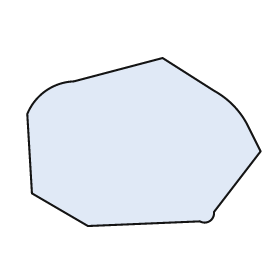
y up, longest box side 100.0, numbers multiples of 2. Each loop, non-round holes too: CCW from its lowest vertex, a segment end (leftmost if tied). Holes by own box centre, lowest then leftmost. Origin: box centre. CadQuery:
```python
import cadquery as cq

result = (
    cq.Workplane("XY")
    .moveTo(-24.0, -36.0)
    .lineTo(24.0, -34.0)
    .threePointArc((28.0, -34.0), (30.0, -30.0))
    .lineTo(50.0, -4.0)
    .lineTo(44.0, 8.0)
    .threePointArc((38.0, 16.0), (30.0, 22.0))
    .lineTo(8.0, 36.0)
    .lineTo(-30.0, 26.0)
    .threePointArc((-42.0, 22.0), (-50.0, 12.0))
    .lineTo(-48.0, -22.0)
    .close()
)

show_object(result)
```